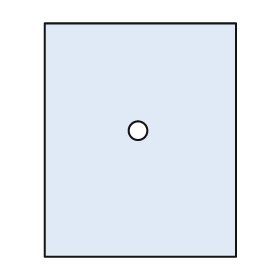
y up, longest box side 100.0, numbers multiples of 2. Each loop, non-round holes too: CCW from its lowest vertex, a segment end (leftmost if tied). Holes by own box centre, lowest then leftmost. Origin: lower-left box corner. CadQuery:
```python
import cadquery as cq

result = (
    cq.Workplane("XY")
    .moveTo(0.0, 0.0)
    .lineTo(82.0, 0.0)
    .lineTo(82.0, 100.0)
    .lineTo(0.0, 100.0)
    .close()
    .moveTo(40.0, 54.0)
    .circle(4.0)
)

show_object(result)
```